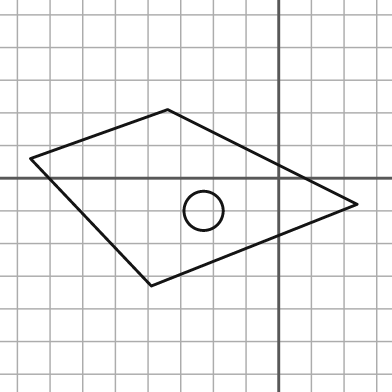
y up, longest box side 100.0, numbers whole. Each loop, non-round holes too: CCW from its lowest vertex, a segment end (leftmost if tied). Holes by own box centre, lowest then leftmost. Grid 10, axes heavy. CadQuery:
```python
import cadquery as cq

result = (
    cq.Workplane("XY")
    .moveTo(-39.0, -33.0)
    .lineTo(24.0, -8.0)
    .lineTo(-34.0, 21.0)
    .lineTo(-76.0, 6.0)
    .close()
    .moveTo(-23.0, -10.0)
    .circle(6.0)
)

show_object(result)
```